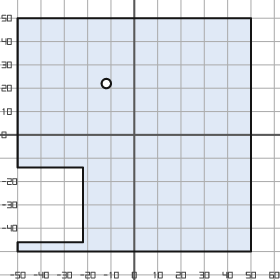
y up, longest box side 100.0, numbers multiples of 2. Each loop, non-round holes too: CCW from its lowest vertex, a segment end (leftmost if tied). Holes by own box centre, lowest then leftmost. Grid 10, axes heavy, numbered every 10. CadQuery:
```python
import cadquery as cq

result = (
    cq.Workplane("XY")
    .moveTo(-50.0, -50.0)
    .lineTo(50.0, -50.0)
    .lineTo(50.0, 50.0)
    .lineTo(-50.0, 50.0)
    .lineTo(-50.0, -14.0)
    .lineTo(-22.0, -14.0)
    .lineTo(-22.0, -46.0)
    .lineTo(-50.0, -46.0)
    .close()
    .moveTo(-12.0, 22.0)
    .circle(2.0)
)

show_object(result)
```